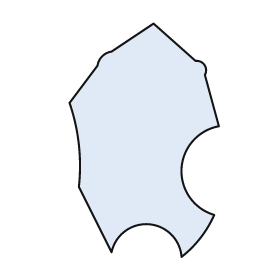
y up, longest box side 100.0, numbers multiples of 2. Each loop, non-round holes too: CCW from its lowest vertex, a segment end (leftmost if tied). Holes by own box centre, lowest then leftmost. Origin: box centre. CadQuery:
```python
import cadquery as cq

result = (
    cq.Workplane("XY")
    .moveTo(16.0, -50.0)
    .threePointArc((24.0, -42.0), (30.0, -32.0))
    .threePointArc((16.0, -12.0), (32.0, 6.0))
    .lineTo(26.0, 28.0)
    .threePointArc((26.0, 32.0), (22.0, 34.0))
    .lineTo(4.0, 50.0)
    .lineTo(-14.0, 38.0)
    .threePointArc((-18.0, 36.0), (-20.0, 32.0))
    .lineTo(-32.0, 16.0)
    .threePointArc((-28.0, -2.0), (-28.0, -20.0))
    .lineTo(-14.0, -48.0)
    .threePointArc((2.0, -36.0), (16.0, -50.0))
    .close()
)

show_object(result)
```